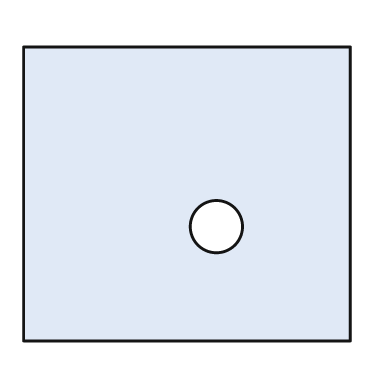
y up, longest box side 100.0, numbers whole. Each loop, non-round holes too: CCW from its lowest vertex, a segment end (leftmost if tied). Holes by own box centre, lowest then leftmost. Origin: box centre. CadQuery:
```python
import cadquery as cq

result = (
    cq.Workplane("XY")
    .moveTo(-50.0, -45.0)
    .lineTo(50.0, -45.0)
    .lineTo(50.0, 45.0)
    .lineTo(-50.0, 45.0)
    .close()
    .moveTo(9.0, -10.0)
    .circle(8.0)
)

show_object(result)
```